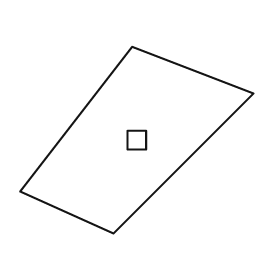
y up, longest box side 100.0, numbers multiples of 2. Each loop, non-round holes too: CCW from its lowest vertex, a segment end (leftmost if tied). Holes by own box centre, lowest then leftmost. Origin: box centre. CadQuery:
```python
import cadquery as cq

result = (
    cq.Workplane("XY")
    .moveTo(-10.0, -40.0)
    .lineTo(50.0, 20.0)
    .lineTo(-2.0, 40.0)
    .lineTo(-50.0, -22.0)
    .close()
    .moveTo(-4.0, -4.0)
    .lineTo(4.0, -4.0)
    .lineTo(4.0, 4.0)
    .lineTo(-4.0, 4.0)
    .close()
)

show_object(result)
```